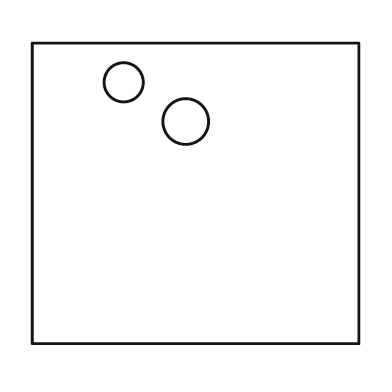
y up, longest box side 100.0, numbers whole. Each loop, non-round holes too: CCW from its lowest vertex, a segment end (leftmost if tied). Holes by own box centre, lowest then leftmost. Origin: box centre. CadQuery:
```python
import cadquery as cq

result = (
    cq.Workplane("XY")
    .moveTo(-50.0, -46.0)
    .lineTo(50.0, -46.0)
    .lineTo(50.0, 46.0)
    .lineTo(-50.0, 46.0)
    .close()
    .moveTo(-3.0, 22.0)
    .circle(7.0)
    .moveTo(-22.0, 34.0)
    .circle(6.0)
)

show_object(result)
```